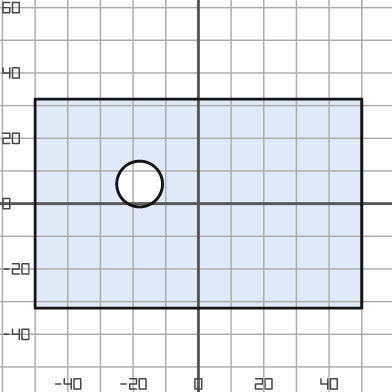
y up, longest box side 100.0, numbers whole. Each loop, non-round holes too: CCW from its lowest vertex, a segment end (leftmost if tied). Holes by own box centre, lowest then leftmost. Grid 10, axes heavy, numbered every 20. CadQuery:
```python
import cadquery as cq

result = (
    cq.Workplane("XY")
    .moveTo(-50.0, -32.0)
    .lineTo(50.0, -32.0)
    .lineTo(50.0, 32.0)
    .lineTo(-50.0, 32.0)
    .close()
    .moveTo(-18.0, 6.0)
    .circle(7.0)
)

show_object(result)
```